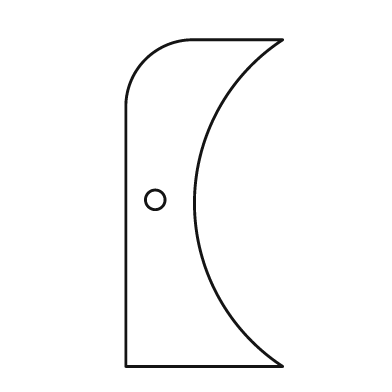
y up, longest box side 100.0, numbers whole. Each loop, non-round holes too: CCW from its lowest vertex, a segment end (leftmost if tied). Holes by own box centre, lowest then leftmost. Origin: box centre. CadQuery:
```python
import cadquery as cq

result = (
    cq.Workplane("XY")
    .moveTo(-24.0, -50.0)
    .lineTo(24.0, -50.0)
    .threePointArc((-3.0, 0.0), (24.0, 50.0))
    .lineTo(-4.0, 50.0)
    .threePointArc((-18.0, 44.0), (-24.0, 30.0))
    .close()
    .moveTo(-15.0, 1.0)
    .circle(3.0)
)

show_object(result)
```